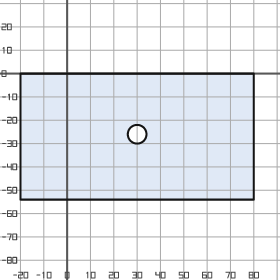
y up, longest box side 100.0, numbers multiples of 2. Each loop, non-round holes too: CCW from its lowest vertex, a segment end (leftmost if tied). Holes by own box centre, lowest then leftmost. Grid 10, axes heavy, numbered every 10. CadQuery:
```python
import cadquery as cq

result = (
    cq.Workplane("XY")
    .moveTo(-20.0, -54.0)
    .lineTo(80.0, -54.0)
    .lineTo(80.0, 0.0)
    .lineTo(-20.0, 0.0)
    .close()
    .moveTo(30.0, -26.0)
    .circle(4.0)
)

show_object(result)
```